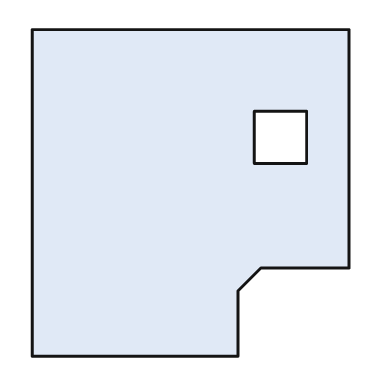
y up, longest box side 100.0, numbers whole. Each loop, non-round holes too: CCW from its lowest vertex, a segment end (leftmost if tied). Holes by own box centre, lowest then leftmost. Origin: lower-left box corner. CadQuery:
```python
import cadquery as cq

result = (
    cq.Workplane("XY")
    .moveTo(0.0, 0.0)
    .lineTo(63.0, 0.0)
    .lineTo(63.0, 20.0)
    .lineTo(70.0, 27.0)
    .lineTo(97.0, 27.0)
    .lineTo(97.0, 100.0)
    .lineTo(0.0, 100.0)
    .close()
    .moveTo(68.0, 59.0)
    .lineTo(84.0, 59.0)
    .lineTo(84.0, 75.0)
    .lineTo(68.0, 75.0)
    .close()
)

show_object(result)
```